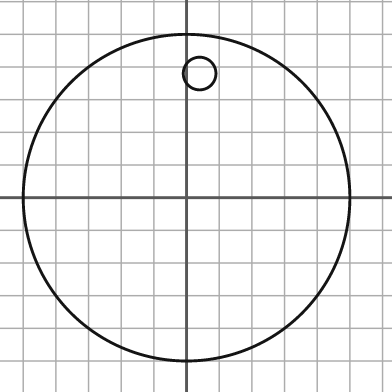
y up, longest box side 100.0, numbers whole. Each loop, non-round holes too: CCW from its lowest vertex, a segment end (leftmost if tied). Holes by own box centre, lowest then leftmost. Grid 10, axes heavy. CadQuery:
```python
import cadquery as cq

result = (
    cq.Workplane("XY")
    .moveTo(0.0, 0.0)
    .circle(50.0)
    .moveTo(4.0, 38.0)
    .circle(5.0)
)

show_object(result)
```